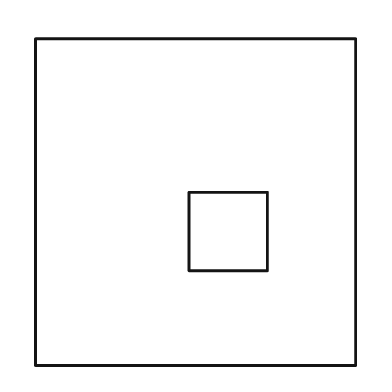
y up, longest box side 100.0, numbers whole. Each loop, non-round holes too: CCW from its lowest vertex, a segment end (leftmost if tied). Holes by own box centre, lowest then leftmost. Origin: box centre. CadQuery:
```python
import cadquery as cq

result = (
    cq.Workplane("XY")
    .moveTo(-49.0, -50.0)
    .lineTo(49.0, -50.0)
    .lineTo(49.0, 50.0)
    .lineTo(-49.0, 50.0)
    .close()
    .moveTo(-2.0, -21.0)
    .lineTo(22.0, -21.0)
    .lineTo(22.0, 3.0)
    .lineTo(-2.0, 3.0)
    .close()
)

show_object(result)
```